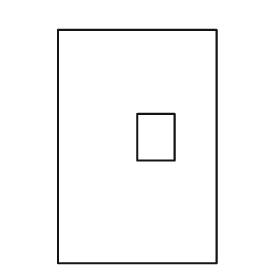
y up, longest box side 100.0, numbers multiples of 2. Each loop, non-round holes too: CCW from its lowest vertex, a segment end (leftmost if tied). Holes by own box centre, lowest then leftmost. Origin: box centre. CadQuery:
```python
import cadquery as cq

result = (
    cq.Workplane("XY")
    .moveTo(-34.0, -50.0)
    .lineTo(34.0, -50.0)
    .lineTo(34.0, 50.0)
    .lineTo(-34.0, 50.0)
    .close()
    .moveTo(0.0, -6.0)
    .lineTo(16.0, -6.0)
    .lineTo(16.0, 14.0)
    .lineTo(0.0, 14.0)
    .close()
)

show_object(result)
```